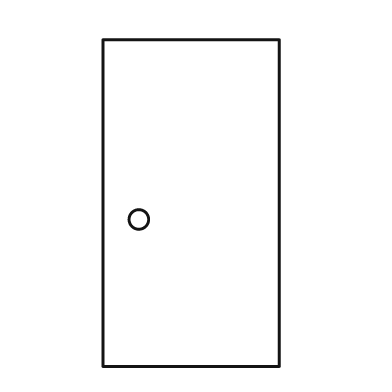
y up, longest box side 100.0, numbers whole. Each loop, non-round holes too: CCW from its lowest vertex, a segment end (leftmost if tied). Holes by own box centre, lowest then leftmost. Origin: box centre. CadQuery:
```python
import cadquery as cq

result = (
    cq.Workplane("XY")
    .moveTo(-27.0, -50.0)
    .lineTo(27.0, -50.0)
    .lineTo(27.0, 50.0)
    .lineTo(-27.0, 50.0)
    .close()
    .moveTo(-16.0, -5.0)
    .circle(3.0)
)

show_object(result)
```